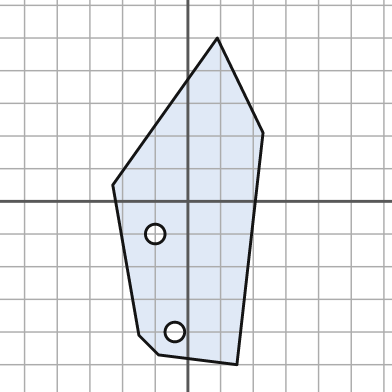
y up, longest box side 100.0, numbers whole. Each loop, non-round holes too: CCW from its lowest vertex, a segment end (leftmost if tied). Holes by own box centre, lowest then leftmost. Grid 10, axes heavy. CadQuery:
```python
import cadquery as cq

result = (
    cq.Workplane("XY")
    .moveTo(15.0, -50.0)
    .lineTo(23.0, 21.0)
    .lineTo(9.0, 50.0)
    .lineTo(-23.0, 5.0)
    .lineTo(-15.0, -41.0)
    .lineTo(-9.0, -47.0)
    .close()
    .moveTo(-4.0, -40.0)
    .circle(3.0)
    .moveTo(-10.0, -10.0)
    .circle(3.0)
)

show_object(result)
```